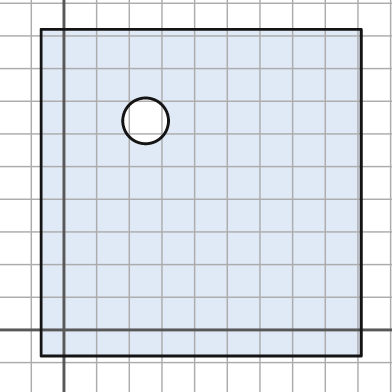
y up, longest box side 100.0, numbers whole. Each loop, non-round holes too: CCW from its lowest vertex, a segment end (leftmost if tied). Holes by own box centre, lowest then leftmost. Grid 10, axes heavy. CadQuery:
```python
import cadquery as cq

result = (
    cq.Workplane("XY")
    .moveTo(-7.0, -8.0)
    .lineTo(91.0, -8.0)
    .lineTo(91.0, 92.0)
    .lineTo(-7.0, 92.0)
    .close()
    .moveTo(25.0, 64.0)
    .circle(7.0)
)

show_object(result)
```